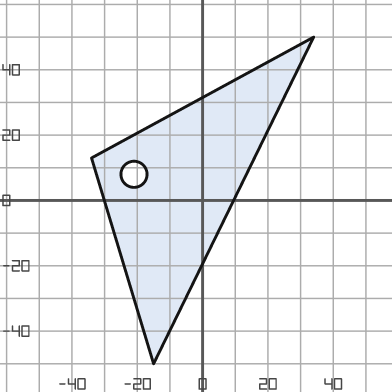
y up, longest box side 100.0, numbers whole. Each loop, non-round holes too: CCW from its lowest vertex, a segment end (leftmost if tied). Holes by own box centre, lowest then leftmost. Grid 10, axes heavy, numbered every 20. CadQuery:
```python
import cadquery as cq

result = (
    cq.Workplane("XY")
    .moveTo(-15.0, -50.0)
    .lineTo(34.0, 50.0)
    .lineTo(-34.0, 13.0)
    .close()
    .moveTo(-21.0, 8.0)
    .circle(4.0)
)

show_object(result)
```